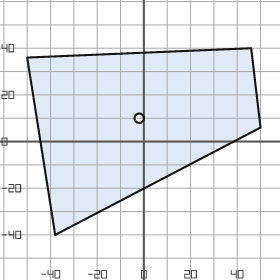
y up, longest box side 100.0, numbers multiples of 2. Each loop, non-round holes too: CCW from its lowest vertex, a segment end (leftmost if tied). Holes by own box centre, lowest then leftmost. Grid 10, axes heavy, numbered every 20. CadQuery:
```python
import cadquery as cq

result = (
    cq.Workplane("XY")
    .moveTo(-38.0, -40.0)
    .lineTo(50.0, 6.0)
    .lineTo(46.0, 40.0)
    .lineTo(-50.0, 36.0)
    .close()
    .moveTo(-2.0, 10.0)
    .circle(2.0)
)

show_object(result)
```